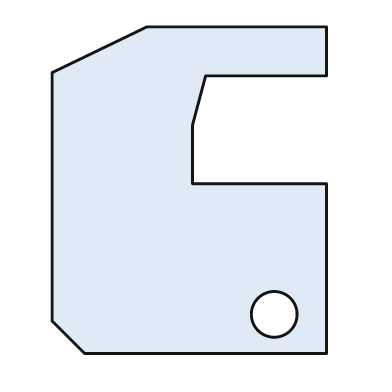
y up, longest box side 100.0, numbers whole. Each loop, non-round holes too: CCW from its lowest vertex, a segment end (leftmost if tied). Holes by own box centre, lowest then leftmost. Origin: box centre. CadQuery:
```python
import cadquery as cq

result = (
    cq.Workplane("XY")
    .moveTo(-32.0, -50.0)
    .lineTo(42.0, -50.0)
    .lineTo(42.0, 2.0)
    .lineTo(1.0, 2.0)
    .lineTo(1.0, 20.0)
    .lineTo(5.0, 35.0)
    .lineTo(42.0, 35.0)
    .lineTo(42.0, 50.0)
    .lineTo(-13.0, 50.0)
    .lineTo(-42.0, 36.0)
    .lineTo(-42.0, -40.0)
    .close()
    .moveTo(26.0, -38.0)
    .circle(7.0)
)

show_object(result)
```